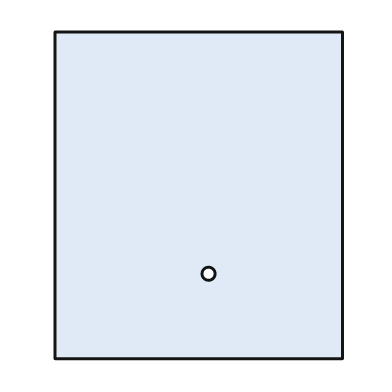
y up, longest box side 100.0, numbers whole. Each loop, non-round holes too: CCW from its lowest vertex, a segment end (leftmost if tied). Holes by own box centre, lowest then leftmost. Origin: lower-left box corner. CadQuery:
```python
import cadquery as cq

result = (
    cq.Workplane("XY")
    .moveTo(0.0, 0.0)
    .lineTo(88.0, 0.0)
    .lineTo(88.0, 100.0)
    .lineTo(0.0, 100.0)
    .close()
    .moveTo(47.0, 26.0)
    .circle(2.0)
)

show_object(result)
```